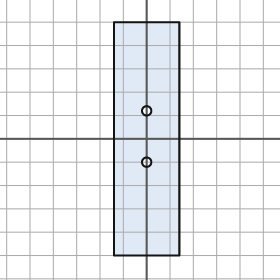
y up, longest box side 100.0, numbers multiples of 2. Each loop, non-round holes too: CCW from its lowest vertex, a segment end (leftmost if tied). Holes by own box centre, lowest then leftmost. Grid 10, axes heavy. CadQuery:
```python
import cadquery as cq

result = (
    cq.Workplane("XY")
    .moveTo(-14.0, -50.0)
    .lineTo(14.0, -50.0)
    .lineTo(14.0, 50.0)
    .lineTo(-14.0, 50.0)
    .close()
    .moveTo(0.0, -10.0)
    .circle(2.0)
    .moveTo(0.0, 12.0)
    .circle(2.0)
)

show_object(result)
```